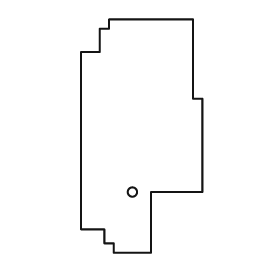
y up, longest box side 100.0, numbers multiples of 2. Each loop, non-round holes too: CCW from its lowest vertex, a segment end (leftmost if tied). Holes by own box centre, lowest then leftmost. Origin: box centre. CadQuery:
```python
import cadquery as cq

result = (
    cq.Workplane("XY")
    .moveTo(-12.0, -50.0)
    .lineTo(4.0, -50.0)
    .lineTo(4.0, -24.0)
    .lineTo(26.0, -24.0)
    .lineTo(26.0, 16.0)
    .lineTo(22.0, 16.0)
    .lineTo(22.0, 50.0)
    .lineTo(-14.0, 50.0)
    .lineTo(-14.0, 46.0)
    .lineTo(-18.0, 46.0)
    .lineTo(-18.0, 36.0)
    .lineTo(-26.0, 36.0)
    .lineTo(-26.0, -40.0)
    .lineTo(-16.0, -40.0)
    .lineTo(-16.0, -46.0)
    .lineTo(-12.0, -46.0)
    .close()
    .moveTo(-4.0, -24.0)
    .circle(2.0)
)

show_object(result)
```